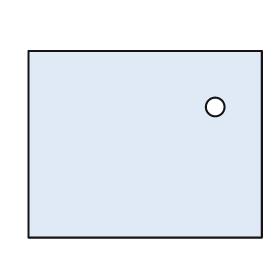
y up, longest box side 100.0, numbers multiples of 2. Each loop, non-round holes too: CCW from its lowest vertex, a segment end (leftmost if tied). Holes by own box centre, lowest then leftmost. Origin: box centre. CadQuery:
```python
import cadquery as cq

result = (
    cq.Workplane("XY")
    .moveTo(-50.0, -40.0)
    .lineTo(50.0, -40.0)
    .lineTo(50.0, 40.0)
    .lineTo(-50.0, 40.0)
    .close()
    .moveTo(30.0, 16.0)
    .circle(4.0)
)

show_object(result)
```